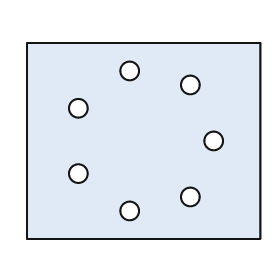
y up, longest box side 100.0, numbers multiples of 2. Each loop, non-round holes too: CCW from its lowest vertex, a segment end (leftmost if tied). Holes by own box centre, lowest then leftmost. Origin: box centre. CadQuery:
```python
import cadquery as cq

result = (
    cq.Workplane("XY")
    .moveTo(-50.0, -42.0)
    .lineTo(50.0, -42.0)
    .lineTo(50.0, 42.0)
    .lineTo(-50.0, 42.0)
    .close()
    .moveTo(-6.0, -30.0)
    .circle(4.0)
    .moveTo(20.0, -24.0)
    .circle(4.0)
    .moveTo(-28.0, -14.0)
    .circle(4.0)
    .moveTo(30.0, 0.0)
    .circle(4.0)
    .moveTo(-28.0, 14.0)
    .circle(4.0)
    .moveTo(20.0, 24.0)
    .circle(4.0)
    .moveTo(-6.0, 30.0)
    .circle(4.0)
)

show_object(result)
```